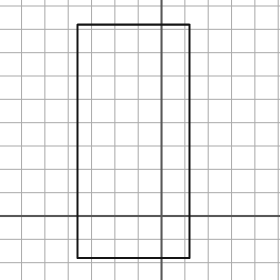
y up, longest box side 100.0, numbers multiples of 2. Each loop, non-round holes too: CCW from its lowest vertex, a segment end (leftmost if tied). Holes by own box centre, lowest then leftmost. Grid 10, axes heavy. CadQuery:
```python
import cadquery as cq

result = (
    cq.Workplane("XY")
    .moveTo(-36.0, -18.0)
    .lineTo(12.0, -18.0)
    .lineTo(12.0, 82.0)
    .lineTo(-36.0, 82.0)
    .close()
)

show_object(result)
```